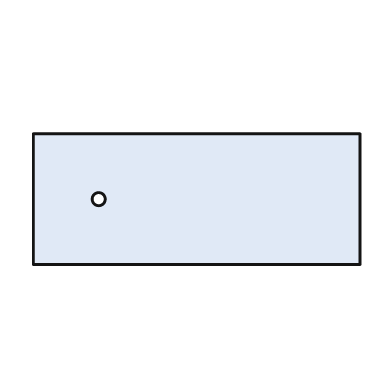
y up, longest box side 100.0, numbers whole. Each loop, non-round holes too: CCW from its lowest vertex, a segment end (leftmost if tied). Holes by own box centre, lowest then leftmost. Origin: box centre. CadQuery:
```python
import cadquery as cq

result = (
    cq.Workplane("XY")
    .moveTo(-50.0, -20.0)
    .lineTo(50.0, -20.0)
    .lineTo(50.0, 20.0)
    .lineTo(-50.0, 20.0)
    .close()
    .moveTo(-30.0, 0.0)
    .circle(2.0)
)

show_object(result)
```